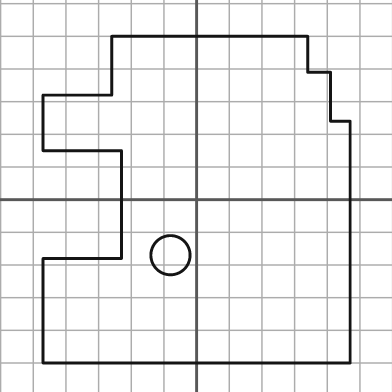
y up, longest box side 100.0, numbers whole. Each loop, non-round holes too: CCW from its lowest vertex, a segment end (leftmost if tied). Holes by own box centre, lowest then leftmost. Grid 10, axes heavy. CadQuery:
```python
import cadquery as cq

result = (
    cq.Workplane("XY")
    .moveTo(-47.0, -50.0)
    .lineTo(47.0, -50.0)
    .lineTo(47.0, 24.0)
    .lineTo(41.0, 24.0)
    .lineTo(41.0, 39.0)
    .lineTo(34.0, 39.0)
    .lineTo(34.0, 50.0)
    .lineTo(-26.0, 50.0)
    .lineTo(-26.0, 32.0)
    .lineTo(-47.0, 32.0)
    .lineTo(-47.0, 15.0)
    .lineTo(-23.0, 15.0)
    .lineTo(-23.0, -18.0)
    .lineTo(-47.0, -18.0)
    .close()
    .moveTo(-8.0, -17.0)
    .circle(6.0)
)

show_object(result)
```